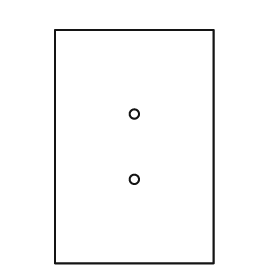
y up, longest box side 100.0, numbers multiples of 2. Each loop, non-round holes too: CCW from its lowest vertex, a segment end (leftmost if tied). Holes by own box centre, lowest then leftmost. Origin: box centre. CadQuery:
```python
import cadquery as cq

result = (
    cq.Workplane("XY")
    .moveTo(-34.0, -50.0)
    .lineTo(34.0, -50.0)
    .lineTo(34.0, 50.0)
    .lineTo(-34.0, 50.0)
    .close()
    .moveTo(0.0, -14.0)
    .circle(2.0)
    .moveTo(0.0, 14.0)
    .circle(2.0)
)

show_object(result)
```